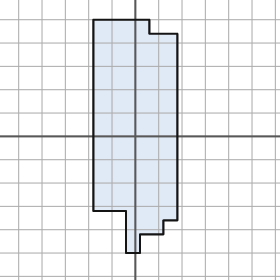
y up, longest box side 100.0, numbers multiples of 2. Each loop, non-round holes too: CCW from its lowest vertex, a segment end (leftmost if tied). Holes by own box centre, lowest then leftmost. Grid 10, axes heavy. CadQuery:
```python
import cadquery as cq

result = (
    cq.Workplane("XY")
    .moveTo(-4.0, -50.0)
    .lineTo(2.0, -50.0)
    .lineTo(2.0, -42.0)
    .lineTo(12.0, -42.0)
    .lineTo(12.0, -36.0)
    .lineTo(18.0, -36.0)
    .lineTo(18.0, 44.0)
    .lineTo(6.0, 44.0)
    .lineTo(6.0, 50.0)
    .lineTo(-18.0, 50.0)
    .lineTo(-18.0, -32.0)
    .lineTo(-4.0, -32.0)
    .close()
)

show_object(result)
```